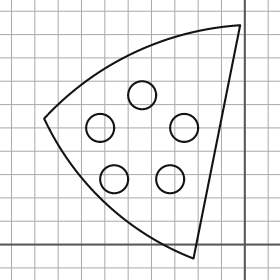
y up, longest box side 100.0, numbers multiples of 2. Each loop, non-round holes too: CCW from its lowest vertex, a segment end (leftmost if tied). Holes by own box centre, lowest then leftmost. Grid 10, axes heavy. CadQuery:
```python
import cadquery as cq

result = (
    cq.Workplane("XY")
    .moveTo(-22.0, -6.0)
    .lineTo(-2.0, 94.0)
    .threePointArc((-48.0, 82.0), (-86.0, 54.0))
    .threePointArc((-60.0, 18.0), (-22.0, -6.0))
    .close()
    .moveTo(-56.0, 28.0)
    .circle(6.0)
    .moveTo(-32.0, 28.0)
    .circle(6.0)
    .moveTo(-62.0, 50.0)
    .circle(6.0)
    .moveTo(-26.0, 50.0)
    .circle(6.0)
    .moveTo(-44.0, 64.0)
    .circle(6.0)
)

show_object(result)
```